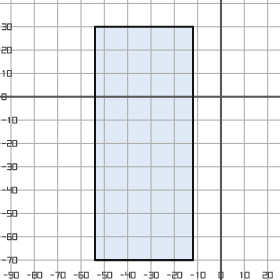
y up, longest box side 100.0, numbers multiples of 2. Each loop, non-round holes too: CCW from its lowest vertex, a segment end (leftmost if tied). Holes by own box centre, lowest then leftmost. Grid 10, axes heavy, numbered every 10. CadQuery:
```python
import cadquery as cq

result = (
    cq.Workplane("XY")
    .moveTo(-54.0, -70.0)
    .lineTo(-12.0, -70.0)
    .lineTo(-12.0, 30.0)
    .lineTo(-54.0, 30.0)
    .close()
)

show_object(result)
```